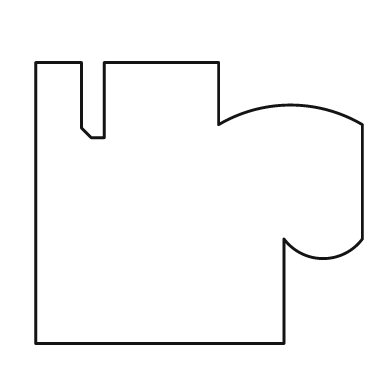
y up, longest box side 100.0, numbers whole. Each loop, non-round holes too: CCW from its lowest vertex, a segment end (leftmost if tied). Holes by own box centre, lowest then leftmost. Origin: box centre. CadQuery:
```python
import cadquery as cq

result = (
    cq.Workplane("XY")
    .moveTo(-50.0, -43.0)
    .lineTo(26.0, -43.0)
    .lineTo(26.0, -11.0)
    .threePointArc((38.0, -17.0), (50.0, -11.0))
    .lineTo(50.0, 24.0)
    .threePointArc((28.0, 30.0), (6.0, 24.0))
    .lineTo(6.0, 43.0)
    .lineTo(-29.0, 43.0)
    .lineTo(-29.0, 20.0)
    .lineTo(-33.0, 20.0)
    .lineTo(-36.0, 23.0)
    .lineTo(-36.0, 43.0)
    .lineTo(-50.0, 43.0)
    .close()
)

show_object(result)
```